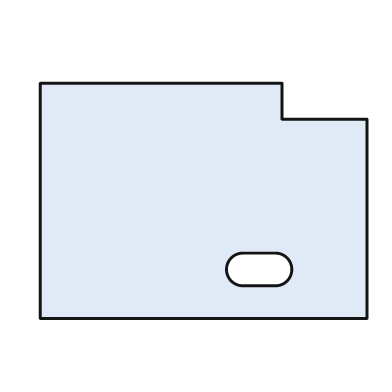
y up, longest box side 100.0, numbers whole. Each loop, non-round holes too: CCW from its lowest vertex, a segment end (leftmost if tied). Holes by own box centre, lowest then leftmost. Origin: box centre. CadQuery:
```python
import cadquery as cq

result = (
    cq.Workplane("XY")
    .moveTo(-50.0, -36.0)
    .lineTo(50.0, -36.0)
    .lineTo(50.0, 25.0)
    .lineTo(24.0, 25.0)
    .lineTo(24.0, 36.0)
    .lineTo(-50.0, 36.0)
    .close()
    .moveTo(12.0, -26.0)
    .lineTo(22.0, -26.0)
    .threePointArc((27.0, -21.0), (22.0, -16.0))
    .lineTo(12.0, -16.0)
    .threePointArc((7.0, -21.0), (12.0, -26.0))
    .close()
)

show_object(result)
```